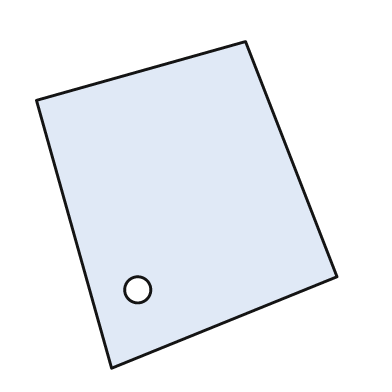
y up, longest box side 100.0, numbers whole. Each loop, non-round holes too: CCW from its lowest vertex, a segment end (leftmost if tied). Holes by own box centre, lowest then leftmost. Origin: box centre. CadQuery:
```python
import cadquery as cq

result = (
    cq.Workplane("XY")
    .moveTo(-23.0, -50.0)
    .lineTo(46.0, -22.0)
    .lineTo(18.0, 50.0)
    .lineTo(-46.0, 32.0)
    .close()
    .moveTo(-15.0, -26.0)
    .circle(4.0)
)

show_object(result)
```